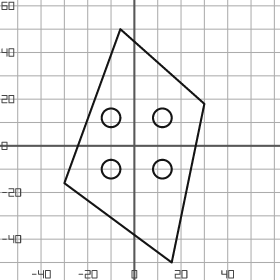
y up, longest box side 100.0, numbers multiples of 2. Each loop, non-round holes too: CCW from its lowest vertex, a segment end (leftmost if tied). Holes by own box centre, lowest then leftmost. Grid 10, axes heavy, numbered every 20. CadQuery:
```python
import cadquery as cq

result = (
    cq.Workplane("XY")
    .moveTo(16.0, -50.0)
    .lineTo(30.0, 18.0)
    .lineTo(-6.0, 50.0)
    .lineTo(-30.0, -16.0)
    .close()
    .moveTo(-10.0, -10.0)
    .circle(4.0)
    .moveTo(12.0, -10.0)
    .circle(4.0)
    .moveTo(-10.0, 12.0)
    .circle(4.0)
    .moveTo(12.0, 12.0)
    .circle(4.0)
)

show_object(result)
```